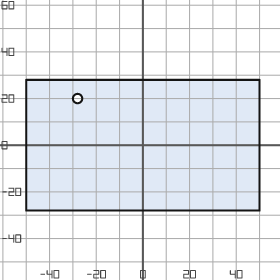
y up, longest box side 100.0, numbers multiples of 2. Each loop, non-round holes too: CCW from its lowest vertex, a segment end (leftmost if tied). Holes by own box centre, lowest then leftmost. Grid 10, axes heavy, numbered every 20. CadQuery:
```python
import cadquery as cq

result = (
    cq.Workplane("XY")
    .moveTo(-50.0, -28.0)
    .lineTo(50.0, -28.0)
    .lineTo(50.0, 28.0)
    .lineTo(-50.0, 28.0)
    .close()
    .moveTo(-28.0, 20.0)
    .circle(2.0)
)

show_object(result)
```